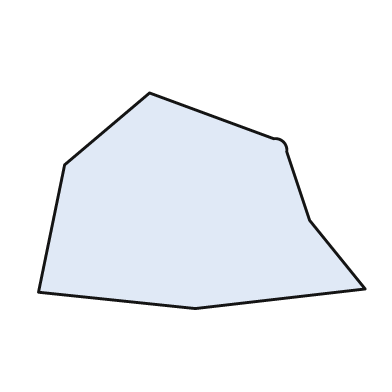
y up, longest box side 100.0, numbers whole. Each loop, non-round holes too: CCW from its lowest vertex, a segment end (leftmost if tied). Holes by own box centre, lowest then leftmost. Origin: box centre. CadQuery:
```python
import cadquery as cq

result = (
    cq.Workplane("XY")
    .moveTo(-2.0, -33.0)
    .lineTo(50.0, -27.0)
    .lineTo(33.0, -6.0)
    .lineTo(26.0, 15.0)
    .threePointArc((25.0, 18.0), (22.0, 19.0))
    .lineTo(-16.0, 33.0)
    .lineTo(-42.0, 11.0)
    .lineTo(-50.0, -28.0)
    .close()
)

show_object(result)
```